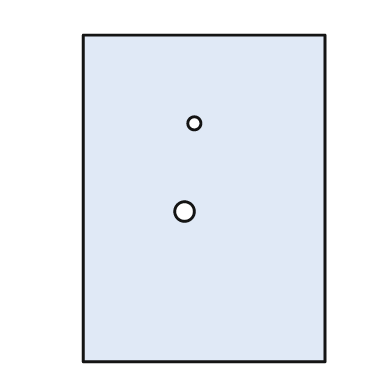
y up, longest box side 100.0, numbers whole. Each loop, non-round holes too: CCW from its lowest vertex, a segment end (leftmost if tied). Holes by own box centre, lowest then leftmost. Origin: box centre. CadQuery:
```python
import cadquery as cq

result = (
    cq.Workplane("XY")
    .moveTo(-37.0, -50.0)
    .lineTo(37.0, -50.0)
    .lineTo(37.0, 50.0)
    .lineTo(-37.0, 50.0)
    .close()
    .moveTo(-6.0, -4.0)
    .circle(3.0)
    .moveTo(-3.0, 23.0)
    .circle(2.0)
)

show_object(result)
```